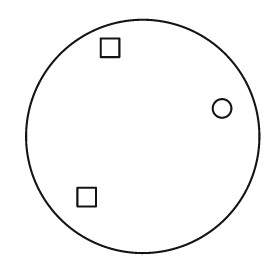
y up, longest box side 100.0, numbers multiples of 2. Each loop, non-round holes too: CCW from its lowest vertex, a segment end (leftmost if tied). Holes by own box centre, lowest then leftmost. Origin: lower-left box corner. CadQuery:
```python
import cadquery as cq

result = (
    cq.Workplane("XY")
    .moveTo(50.0, 50.0)
    .circle(50.0)
    .moveTo(22.0, 20.0)
    .lineTo(30.0, 20.0)
    .lineTo(30.0, 28.0)
    .lineTo(22.0, 28.0)
    .close()
    .moveTo(84.0, 62.0)
    .circle(4.0)
    .moveTo(32.0, 84.0)
    .lineTo(40.0, 84.0)
    .lineTo(40.0, 92.0)
    .lineTo(32.0, 92.0)
    .close()
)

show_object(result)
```